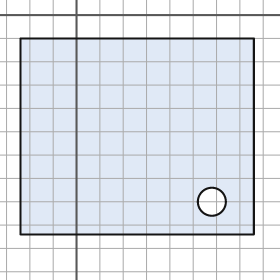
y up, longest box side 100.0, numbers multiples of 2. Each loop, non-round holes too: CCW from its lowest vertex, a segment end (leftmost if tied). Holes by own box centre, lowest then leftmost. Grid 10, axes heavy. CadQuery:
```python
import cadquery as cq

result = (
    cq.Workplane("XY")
    .moveTo(-24.0, -94.0)
    .lineTo(76.0, -94.0)
    .lineTo(76.0, -10.0)
    .lineTo(-24.0, -10.0)
    .close()
    .moveTo(58.0, -80.0)
    .circle(6.0)
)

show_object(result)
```